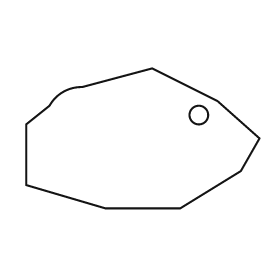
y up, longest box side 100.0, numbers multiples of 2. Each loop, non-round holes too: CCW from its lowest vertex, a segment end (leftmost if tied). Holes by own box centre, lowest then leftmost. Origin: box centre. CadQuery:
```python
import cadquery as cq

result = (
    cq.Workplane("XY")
    .moveTo(-16.0, -30.0)
    .lineTo(16.0, -30.0)
    .lineTo(42.0, -14.0)
    .lineTo(50.0, 0.0)
    .lineTo(32.0, 16.0)
    .lineTo(4.0, 30.0)
    .lineTo(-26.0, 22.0)
    .threePointArc((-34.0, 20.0), (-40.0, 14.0))
    .lineTo(-50.0, 6.0)
    .lineTo(-50.0, -20.0)
    .close()
    .moveTo(24.0, 10.0)
    .circle(4.0)
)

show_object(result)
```